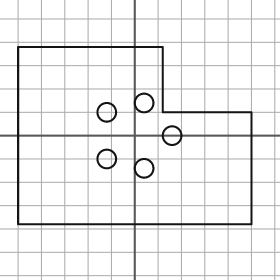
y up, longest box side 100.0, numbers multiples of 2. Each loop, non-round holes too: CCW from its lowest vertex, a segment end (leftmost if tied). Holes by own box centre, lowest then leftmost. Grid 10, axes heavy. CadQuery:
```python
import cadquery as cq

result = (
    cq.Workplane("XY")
    .moveTo(-50.0, -38.0)
    .lineTo(50.0, -38.0)
    .lineTo(50.0, 10.0)
    .lineTo(12.0, 10.0)
    .lineTo(12.0, 38.0)
    .lineTo(-50.0, 38.0)
    .close()
    .moveTo(4.0, -14.0)
    .circle(4.0)
    .moveTo(-12.0, -10.0)
    .circle(4.0)
    .moveTo(16.0, 0.0)
    .circle(4.0)
    .moveTo(-12.0, 10.0)
    .circle(4.0)
    .moveTo(4.0, 14.0)
    .circle(4.0)
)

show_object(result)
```